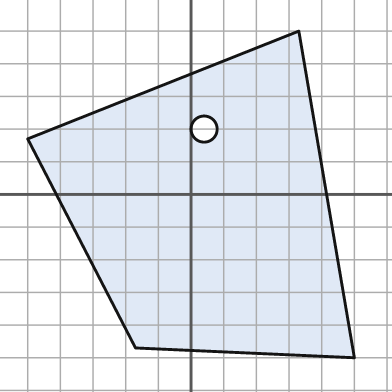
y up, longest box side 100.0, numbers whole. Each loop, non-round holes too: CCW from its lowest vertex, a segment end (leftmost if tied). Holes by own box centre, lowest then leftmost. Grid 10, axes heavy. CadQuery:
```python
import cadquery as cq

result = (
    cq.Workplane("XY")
    .moveTo(50.0, -50.0)
    .lineTo(33.0, 50.0)
    .lineTo(-50.0, 17.0)
    .lineTo(-17.0, -47.0)
    .close()
    .moveTo(4.0, 20.0)
    .circle(4.0)
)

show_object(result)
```